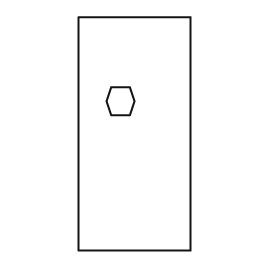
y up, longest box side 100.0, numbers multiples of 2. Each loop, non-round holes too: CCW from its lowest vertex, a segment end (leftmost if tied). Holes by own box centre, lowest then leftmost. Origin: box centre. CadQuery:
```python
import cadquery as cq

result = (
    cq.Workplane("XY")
    .moveTo(-24.0, -50.0)
    .lineTo(24.0, -50.0)
    .lineTo(24.0, 50.0)
    .lineTo(-24.0, 50.0)
    .close()
    .moveTo(-10.0, 8.0)
    .lineTo(-2.0, 8.0)
    .lineTo(0.0, 14.0)
    .lineTo(-2.0, 20.0)
    .lineTo(-10.0, 20.0)
    .lineTo(-12.0, 14.0)
    .close()
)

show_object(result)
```